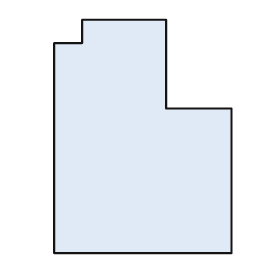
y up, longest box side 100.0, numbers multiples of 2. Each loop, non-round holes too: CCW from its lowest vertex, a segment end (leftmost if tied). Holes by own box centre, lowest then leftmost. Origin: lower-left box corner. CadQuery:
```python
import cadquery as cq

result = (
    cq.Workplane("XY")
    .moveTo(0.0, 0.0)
    .lineTo(76.0, 0.0)
    .lineTo(76.0, 62.0)
    .lineTo(48.0, 62.0)
    .lineTo(48.0, 100.0)
    .lineTo(12.0, 100.0)
    .lineTo(12.0, 90.0)
    .lineTo(0.0, 90.0)
    .close()
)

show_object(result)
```